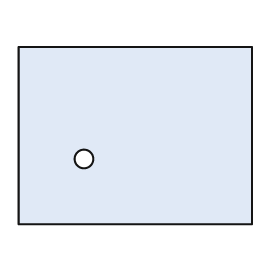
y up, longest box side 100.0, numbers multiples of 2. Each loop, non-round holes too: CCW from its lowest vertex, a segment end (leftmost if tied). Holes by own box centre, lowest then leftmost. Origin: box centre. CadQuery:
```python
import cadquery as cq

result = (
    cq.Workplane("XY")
    .moveTo(-50.0, -38.0)
    .lineTo(50.0, -38.0)
    .lineTo(50.0, 38.0)
    .lineTo(-50.0, 38.0)
    .close()
    .moveTo(-22.0, -10.0)
    .circle(4.0)
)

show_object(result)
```